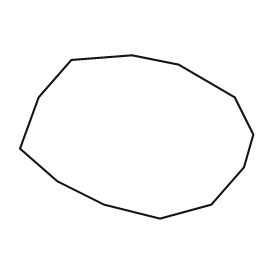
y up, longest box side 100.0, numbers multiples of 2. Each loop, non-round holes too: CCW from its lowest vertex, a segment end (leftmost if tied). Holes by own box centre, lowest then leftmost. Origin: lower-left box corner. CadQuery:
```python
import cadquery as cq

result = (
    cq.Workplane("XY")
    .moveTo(60.0, 0.0)
    .lineTo(82.0, 6.0)
    .lineTo(96.0, 22.0)
    .lineTo(100.0, 36.0)
    .lineTo(92.0, 52.0)
    .lineTo(68.0, 66.0)
    .lineTo(48.0, 70.0)
    .lineTo(22.0, 68.0)
    .lineTo(8.0, 52.0)
    .lineTo(0.0, 30.0)
    .lineTo(16.0, 16.0)
    .lineTo(36.0, 6.0)
    .close()
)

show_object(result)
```